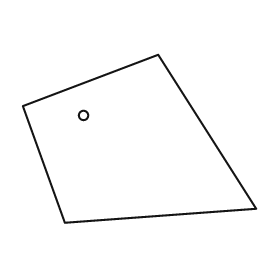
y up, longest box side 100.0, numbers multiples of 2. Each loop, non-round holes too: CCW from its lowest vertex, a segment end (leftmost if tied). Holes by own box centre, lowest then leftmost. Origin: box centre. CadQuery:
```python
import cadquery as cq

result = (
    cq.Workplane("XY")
    .moveTo(-32.0, -36.0)
    .lineTo(50.0, -30.0)
    .lineTo(8.0, 36.0)
    .lineTo(-50.0, 14.0)
    .close()
    .moveTo(-24.0, 10.0)
    .circle(2.0)
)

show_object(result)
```